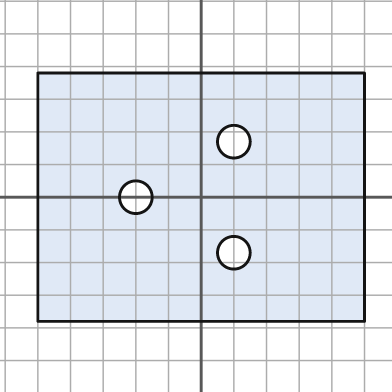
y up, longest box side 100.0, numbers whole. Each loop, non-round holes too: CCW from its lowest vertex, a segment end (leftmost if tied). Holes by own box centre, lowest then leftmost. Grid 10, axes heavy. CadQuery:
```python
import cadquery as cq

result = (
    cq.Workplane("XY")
    .moveTo(-50.0, -38.0)
    .lineTo(50.0, -38.0)
    .lineTo(50.0, 38.0)
    .lineTo(-50.0, 38.0)
    .close()
    .moveTo(10.0, -17.0)
    .circle(5.0)
    .moveTo(-20.0, 0.0)
    .circle(5.0)
    .moveTo(10.0, 17.0)
    .circle(5.0)
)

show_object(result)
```